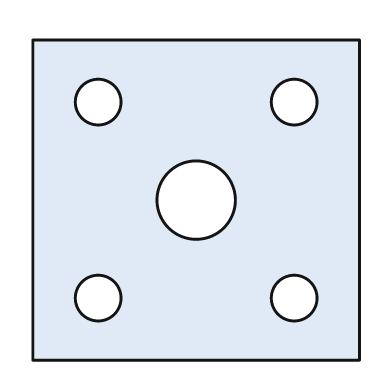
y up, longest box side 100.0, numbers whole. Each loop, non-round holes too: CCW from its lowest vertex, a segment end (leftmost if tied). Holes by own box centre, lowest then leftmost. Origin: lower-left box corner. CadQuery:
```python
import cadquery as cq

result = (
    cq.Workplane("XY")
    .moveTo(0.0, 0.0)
    .lineTo(100.0, 0.0)
    .lineTo(100.0, 98.0)
    .lineTo(0.0, 98.0)
    .close()
    .moveTo(20.0, 19.0)
    .circle(7.0)
    .moveTo(80.0, 19.0)
    .circle(7.0)
    .moveTo(50.0, 49.0)
    .circle(12.0)
    .moveTo(20.0, 79.0)
    .circle(7.0)
    .moveTo(80.0, 79.0)
    .circle(7.0)
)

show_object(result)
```